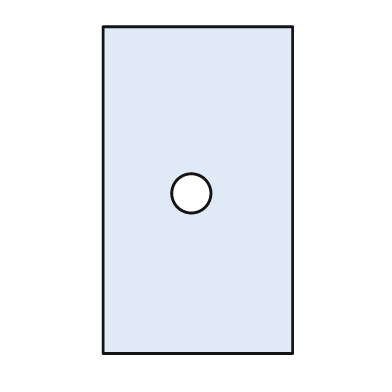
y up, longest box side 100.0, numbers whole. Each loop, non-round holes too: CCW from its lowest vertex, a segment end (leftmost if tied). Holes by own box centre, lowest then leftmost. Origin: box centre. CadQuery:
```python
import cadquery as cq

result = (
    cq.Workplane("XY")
    .moveTo(-29.0, -50.0)
    .lineTo(29.0, -50.0)
    .lineTo(29.0, 50.0)
    .lineTo(-29.0, 50.0)
    .close()
    .moveTo(-2.0, -1.0)
    .circle(6.0)
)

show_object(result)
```